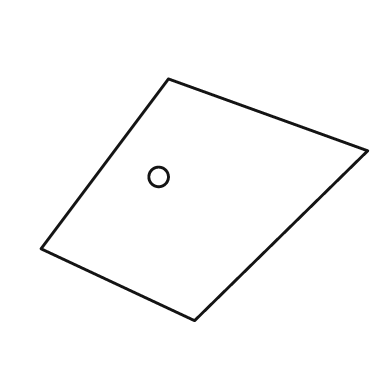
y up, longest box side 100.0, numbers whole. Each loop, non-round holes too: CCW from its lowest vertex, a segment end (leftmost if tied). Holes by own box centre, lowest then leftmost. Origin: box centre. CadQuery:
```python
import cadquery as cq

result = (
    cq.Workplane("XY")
    .moveTo(-3.0, -37.0)
    .lineTo(50.0, 15.0)
    .lineTo(-11.0, 37.0)
    .lineTo(-50.0, -15.0)
    .close()
    .moveTo(-14.0, 7.0)
    .circle(3.0)
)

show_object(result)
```